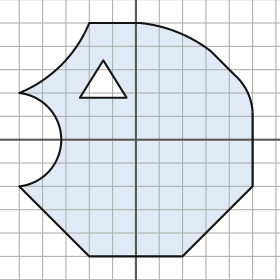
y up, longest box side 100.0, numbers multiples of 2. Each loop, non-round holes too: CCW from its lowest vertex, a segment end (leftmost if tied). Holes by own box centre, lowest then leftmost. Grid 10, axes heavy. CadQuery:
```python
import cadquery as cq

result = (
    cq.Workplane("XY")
    .moveTo(-20.0, -50.0)
    .lineTo(20.0, -50.0)
    .lineTo(50.0, -20.0)
    .lineTo(50.0, 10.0)
    .threePointArc((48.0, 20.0), (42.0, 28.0))
    .lineTo(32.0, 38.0)
    .threePointArc((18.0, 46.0), (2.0, 50.0))
    .lineTo(-20.0, 50.0)
    .threePointArc((-32.0, 32.0), (-50.0, 20.0))
    .threePointArc((-32.0, 0.0), (-50.0, -20.0))
    .close()
    .moveTo(-24.0, 18.0)
    .lineTo(-4.0, 18.0)
    .lineTo(-14.0, 34.0)
    .close()
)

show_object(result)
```